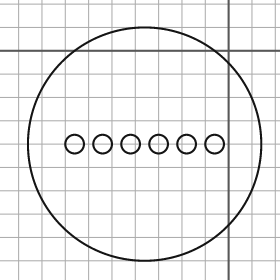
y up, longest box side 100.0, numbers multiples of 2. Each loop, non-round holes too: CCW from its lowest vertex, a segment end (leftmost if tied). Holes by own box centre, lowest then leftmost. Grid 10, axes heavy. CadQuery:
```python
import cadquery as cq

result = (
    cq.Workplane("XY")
    .moveTo(-36.0, -40.0)
    .circle(50.0)
    .moveTo(-66.0, -40.0)
    .circle(4.0)
    .moveTo(-54.0, -40.0)
    .circle(4.0)
    .moveTo(-42.0, -40.0)
    .circle(4.0)
    .moveTo(-30.0, -40.0)
    .circle(4.0)
    .moveTo(-18.0, -40.0)
    .circle(4.0)
    .moveTo(-6.0, -40.0)
    .circle(4.0)
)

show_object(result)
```